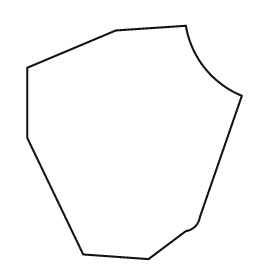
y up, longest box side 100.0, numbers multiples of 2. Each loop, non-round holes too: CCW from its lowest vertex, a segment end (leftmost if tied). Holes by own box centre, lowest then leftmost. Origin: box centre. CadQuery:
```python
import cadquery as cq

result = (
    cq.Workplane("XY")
    .moveTo(6.0, -50.0)
    .lineTo(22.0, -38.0)
    .threePointArc((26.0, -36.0), (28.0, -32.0))
    .lineTo(46.0, 20.0)
    .threePointArc((30.0, 32.0), (22.0, 50.0))
    .lineTo(-8.0, 48.0)
    .lineTo(-46.0, 32.0)
    .lineTo(-46.0, 2.0)
    .lineTo(-22.0, -48.0)
    .close()
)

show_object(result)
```